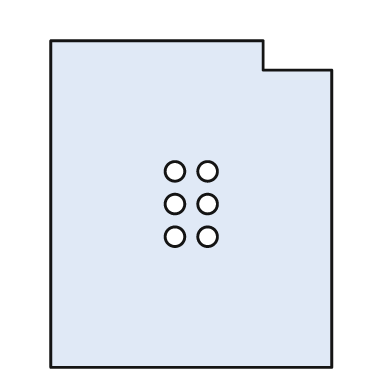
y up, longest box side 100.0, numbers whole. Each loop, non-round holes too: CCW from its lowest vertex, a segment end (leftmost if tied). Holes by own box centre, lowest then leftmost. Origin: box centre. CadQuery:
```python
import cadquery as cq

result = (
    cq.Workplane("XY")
    .moveTo(-43.0, -50.0)
    .lineTo(43.0, -50.0)
    .lineTo(43.0, 41.0)
    .lineTo(22.0, 41.0)
    .lineTo(22.0, 50.0)
    .lineTo(-43.0, 50.0)
    .close()
    .moveTo(-5.0, -10.0)
    .circle(3.0)
    .moveTo(5.0, -10.0)
    .circle(3.0)
    .moveTo(-5.0, 0.0)
    .circle(3.0)
    .moveTo(5.0, 0.0)
    .circle(3.0)
    .moveTo(-5.0, 10.0)
    .circle(3.0)
    .moveTo(5.0, 10.0)
    .circle(3.0)
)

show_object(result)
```